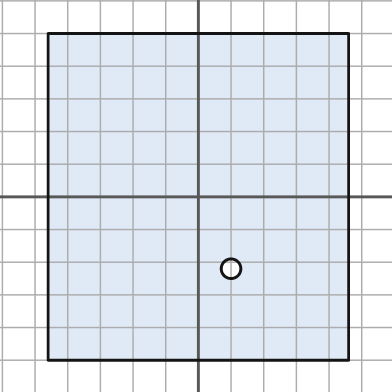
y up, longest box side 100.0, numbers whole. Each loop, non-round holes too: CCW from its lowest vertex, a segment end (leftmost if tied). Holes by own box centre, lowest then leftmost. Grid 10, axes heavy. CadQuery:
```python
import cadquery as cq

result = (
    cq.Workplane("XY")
    .moveTo(-46.0, -50.0)
    .lineTo(46.0, -50.0)
    .lineTo(46.0, 50.0)
    .lineTo(-46.0, 50.0)
    .close()
    .moveTo(10.0, -22.0)
    .circle(3.0)
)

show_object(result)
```